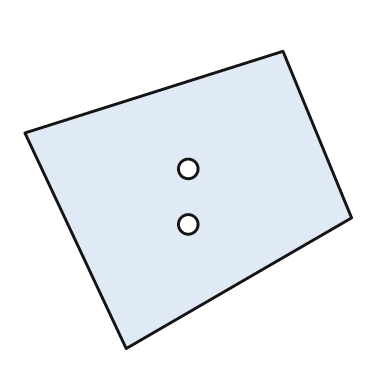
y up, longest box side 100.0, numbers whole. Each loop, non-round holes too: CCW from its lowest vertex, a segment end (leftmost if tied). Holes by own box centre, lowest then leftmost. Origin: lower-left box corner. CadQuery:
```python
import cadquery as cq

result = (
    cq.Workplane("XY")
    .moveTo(31.0, 0.0)
    .lineTo(100.0, 40.0)
    .lineTo(79.0, 91.0)
    .lineTo(0.0, 66.0)
    .close()
    .moveTo(50.0, 38.0)
    .circle(3.0)
    .moveTo(50.0, 55.0)
    .circle(3.0)
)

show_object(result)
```